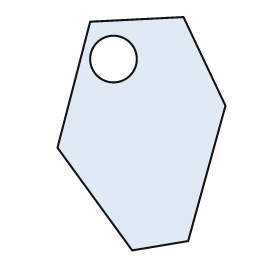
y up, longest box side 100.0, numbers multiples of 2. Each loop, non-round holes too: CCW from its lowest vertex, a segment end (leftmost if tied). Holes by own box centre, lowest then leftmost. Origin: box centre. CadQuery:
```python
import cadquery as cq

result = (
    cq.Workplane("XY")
    .moveTo(-4.0, -50.0)
    .lineTo(20.0, -46.0)
    .lineTo(36.0, 12.0)
    .lineTo(18.0, 50.0)
    .lineTo(-22.0, 48.0)
    .lineTo(-36.0, -6.0)
    .close()
    .moveTo(-12.0, 32.0)
    .circle(10.0)
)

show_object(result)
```